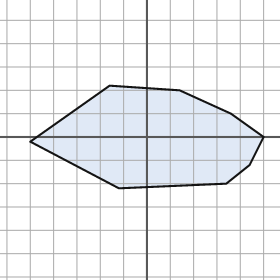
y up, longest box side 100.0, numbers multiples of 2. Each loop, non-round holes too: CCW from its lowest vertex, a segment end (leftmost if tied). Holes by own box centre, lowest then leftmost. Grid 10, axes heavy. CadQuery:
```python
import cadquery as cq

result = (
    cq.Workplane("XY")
    .moveTo(-12.0, -22.0)
    .lineTo(34.0, -20.0)
    .lineTo(44.0, -12.0)
    .lineTo(50.0, 0.0)
    .lineTo(36.0, 10.0)
    .lineTo(14.0, 20.0)
    .lineTo(-16.0, 22.0)
    .lineTo(-50.0, -2.0)
    .close()
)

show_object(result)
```